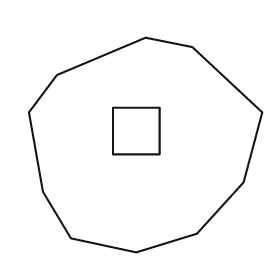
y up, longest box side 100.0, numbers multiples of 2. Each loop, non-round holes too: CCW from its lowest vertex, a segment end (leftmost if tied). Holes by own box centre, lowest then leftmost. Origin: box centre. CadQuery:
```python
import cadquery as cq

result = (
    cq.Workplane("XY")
    .moveTo(-4.0, -46.0)
    .lineTo(22.0, -38.0)
    .lineTo(42.0, -16.0)
    .lineTo(50.0, 14.0)
    .lineTo(20.0, 42.0)
    .lineTo(0.0, 46.0)
    .lineTo(-38.0, 30.0)
    .lineTo(-50.0, 14.0)
    .lineTo(-44.0, -20.0)
    .lineTo(-32.0, -40.0)
    .close()
    .moveTo(-14.0, -4.0)
    .lineTo(6.0, -4.0)
    .lineTo(6.0, 16.0)
    .lineTo(-14.0, 16.0)
    .close()
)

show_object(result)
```